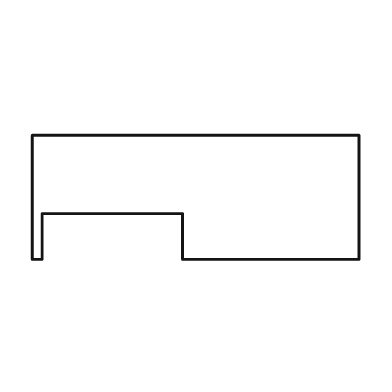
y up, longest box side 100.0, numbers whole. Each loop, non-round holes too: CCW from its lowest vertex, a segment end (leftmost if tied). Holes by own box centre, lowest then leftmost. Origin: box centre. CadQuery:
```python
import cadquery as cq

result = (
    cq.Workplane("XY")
    .moveTo(-50.0, -19.0)
    .lineTo(-47.0, -19.0)
    .lineTo(-47.0, -5.0)
    .lineTo(-4.0, -5.0)
    .lineTo(-4.0, -19.0)
    .lineTo(50.0, -19.0)
    .lineTo(50.0, 19.0)
    .lineTo(-50.0, 19.0)
    .close()
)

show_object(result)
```